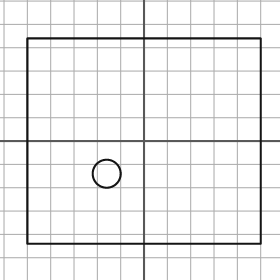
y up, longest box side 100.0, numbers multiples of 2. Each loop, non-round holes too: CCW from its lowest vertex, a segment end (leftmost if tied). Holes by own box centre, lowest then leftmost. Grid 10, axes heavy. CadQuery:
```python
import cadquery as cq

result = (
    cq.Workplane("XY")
    .moveTo(-50.0, -44.0)
    .lineTo(50.0, -44.0)
    .lineTo(50.0, 44.0)
    .lineTo(-50.0, 44.0)
    .close()
    .moveTo(-16.0, -14.0)
    .circle(6.0)
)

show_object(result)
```